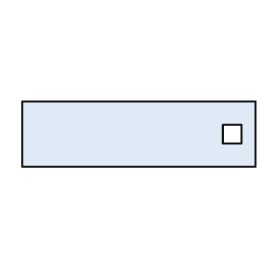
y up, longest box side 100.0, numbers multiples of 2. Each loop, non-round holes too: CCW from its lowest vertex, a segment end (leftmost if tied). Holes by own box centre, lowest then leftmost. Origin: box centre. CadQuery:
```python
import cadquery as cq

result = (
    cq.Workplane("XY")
    .moveTo(-50.0, -14.0)
    .lineTo(50.0, -14.0)
    .lineTo(50.0, 14.0)
    .lineTo(-50.0, 14.0)
    .close()
    .moveTo(36.0, -4.0)
    .lineTo(44.0, -4.0)
    .lineTo(44.0, 4.0)
    .lineTo(36.0, 4.0)
    .close()
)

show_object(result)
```